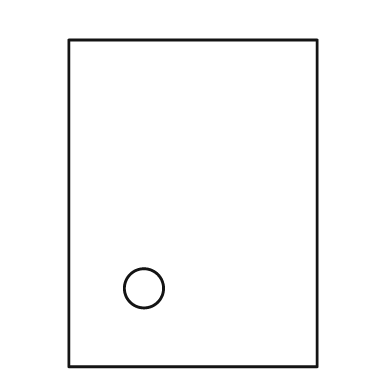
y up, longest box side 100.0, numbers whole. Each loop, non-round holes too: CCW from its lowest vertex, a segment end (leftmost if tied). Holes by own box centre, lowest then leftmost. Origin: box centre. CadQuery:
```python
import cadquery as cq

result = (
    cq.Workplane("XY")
    .moveTo(-38.0, -50.0)
    .lineTo(38.0, -50.0)
    .lineTo(38.0, 50.0)
    .lineTo(-38.0, 50.0)
    .close()
    .moveTo(-15.0, -26.0)
    .circle(6.0)
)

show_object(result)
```